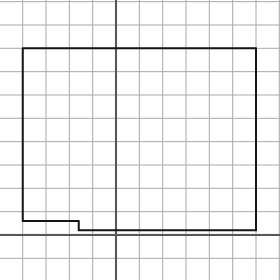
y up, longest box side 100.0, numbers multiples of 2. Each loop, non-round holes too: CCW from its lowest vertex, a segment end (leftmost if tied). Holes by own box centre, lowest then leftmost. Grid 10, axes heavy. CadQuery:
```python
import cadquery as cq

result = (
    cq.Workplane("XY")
    .moveTo(-16.0, 2.0)
    .lineTo(60.0, 2.0)
    .lineTo(60.0, 80.0)
    .lineTo(-40.0, 80.0)
    .lineTo(-40.0, 6.0)
    .lineTo(-16.0, 6.0)
    .close()
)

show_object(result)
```